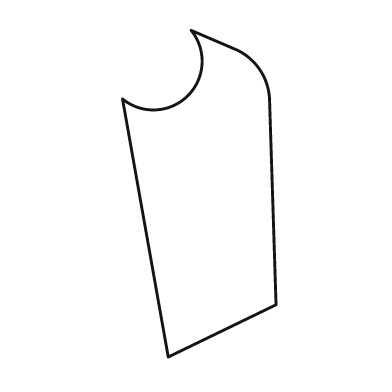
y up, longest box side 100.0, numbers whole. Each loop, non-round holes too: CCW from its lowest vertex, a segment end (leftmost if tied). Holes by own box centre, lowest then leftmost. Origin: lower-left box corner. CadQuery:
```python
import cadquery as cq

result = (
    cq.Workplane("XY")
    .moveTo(14.0, 0.0)
    .lineTo(47.0, 16.0)
    .lineTo(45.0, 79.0)
    .threePointArc((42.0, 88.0), (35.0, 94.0))
    .lineTo(21.0, 100.0)
    .threePointArc((20.0, 80.0), (0.0, 79.0))
    .close()
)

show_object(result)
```